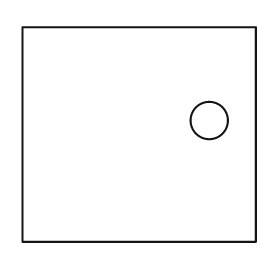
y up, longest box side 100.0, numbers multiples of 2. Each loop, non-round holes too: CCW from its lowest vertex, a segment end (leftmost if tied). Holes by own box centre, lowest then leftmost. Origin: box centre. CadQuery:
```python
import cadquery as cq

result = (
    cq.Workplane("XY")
    .moveTo(-50.0, -46.0)
    .lineTo(50.0, -46.0)
    .lineTo(50.0, 46.0)
    .lineTo(-50.0, 46.0)
    .close()
    .moveTo(30.0, 6.0)
    .circle(8.0)
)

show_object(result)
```